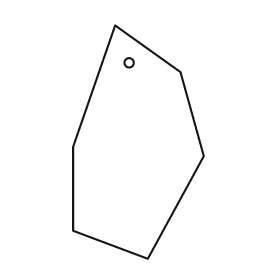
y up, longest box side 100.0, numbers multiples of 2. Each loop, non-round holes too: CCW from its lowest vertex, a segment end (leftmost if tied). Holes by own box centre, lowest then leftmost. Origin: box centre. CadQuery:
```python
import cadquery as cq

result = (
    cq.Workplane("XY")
    .moveTo(4.0, -50.0)
    .lineTo(28.0, -6.0)
    .lineTo(18.0, 30.0)
    .lineTo(-10.0, 50.0)
    .lineTo(-28.0, -2.0)
    .lineTo(-28.0, -38.0)
    .close()
    .moveTo(-4.0, 34.0)
    .circle(2.0)
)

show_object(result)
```